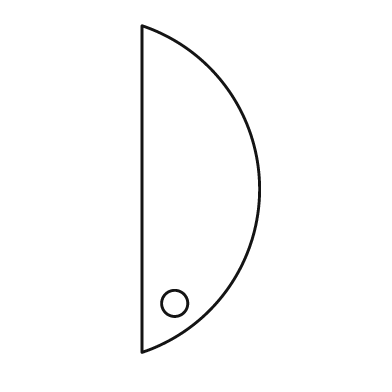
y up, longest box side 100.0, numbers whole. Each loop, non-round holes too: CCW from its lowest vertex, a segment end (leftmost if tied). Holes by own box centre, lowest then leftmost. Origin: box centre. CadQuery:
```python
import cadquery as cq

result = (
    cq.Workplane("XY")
    .moveTo(-18.0, -50.0)
    .threePointArc((18.0, 0.0), (-18.0, 50.0))
    .close()
    .moveTo(-8.0, -35.0)
    .circle(4.0)
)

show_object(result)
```